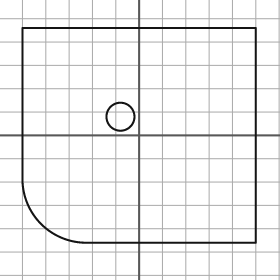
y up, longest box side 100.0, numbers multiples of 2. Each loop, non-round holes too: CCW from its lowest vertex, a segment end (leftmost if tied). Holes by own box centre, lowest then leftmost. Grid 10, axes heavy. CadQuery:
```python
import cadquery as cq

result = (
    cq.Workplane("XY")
    .moveTo(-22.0, -46.0)
    .lineTo(50.0, -46.0)
    .lineTo(50.0, 46.0)
    .lineTo(-50.0, 46.0)
    .lineTo(-50.0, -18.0)
    .threePointArc((-42.0, -38.0), (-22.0, -46.0))
    .close()
    .moveTo(-8.0, 8.0)
    .circle(6.0)
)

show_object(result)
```